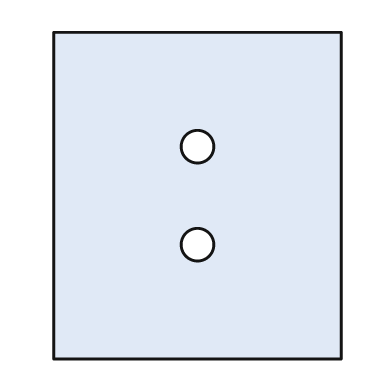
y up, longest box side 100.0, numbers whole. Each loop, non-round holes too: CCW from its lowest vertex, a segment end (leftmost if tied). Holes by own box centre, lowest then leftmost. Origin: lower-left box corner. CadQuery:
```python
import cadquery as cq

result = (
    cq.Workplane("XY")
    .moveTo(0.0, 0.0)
    .lineTo(88.0, 0.0)
    .lineTo(88.0, 100.0)
    .lineTo(0.0, 100.0)
    .close()
    .moveTo(44.0, 35.0)
    .circle(5.0)
    .moveTo(44.0, 65.0)
    .circle(5.0)
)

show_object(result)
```